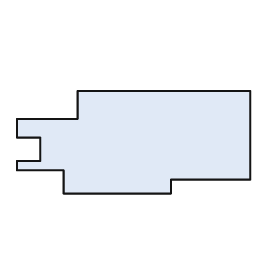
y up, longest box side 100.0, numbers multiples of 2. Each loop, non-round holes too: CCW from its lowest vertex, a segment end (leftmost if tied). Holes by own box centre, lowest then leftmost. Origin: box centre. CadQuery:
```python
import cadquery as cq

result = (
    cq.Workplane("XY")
    .moveTo(-30.0, -22.0)
    .lineTo(16.0, -22.0)
    .lineTo(16.0, -16.0)
    .lineTo(50.0, -16.0)
    .lineTo(50.0, 22.0)
    .lineTo(-24.0, 22.0)
    .lineTo(-24.0, 10.0)
    .lineTo(-50.0, 10.0)
    .lineTo(-50.0, 2.0)
    .lineTo(-40.0, 2.0)
    .lineTo(-40.0, -8.0)
    .lineTo(-50.0, -8.0)
    .lineTo(-50.0, -12.0)
    .lineTo(-30.0, -12.0)
    .close()
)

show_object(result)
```